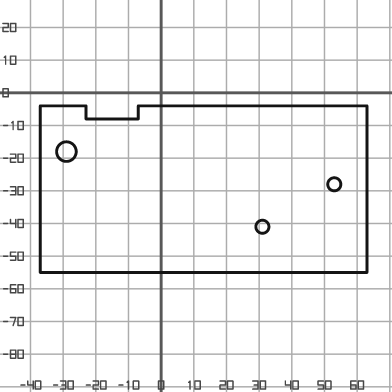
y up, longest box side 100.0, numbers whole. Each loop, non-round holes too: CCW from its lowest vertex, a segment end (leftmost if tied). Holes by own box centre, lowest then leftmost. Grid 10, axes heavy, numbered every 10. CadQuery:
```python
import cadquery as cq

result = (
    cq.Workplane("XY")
    .moveTo(-37.0, -55.0)
    .lineTo(63.0, -55.0)
    .lineTo(63.0, -4.0)
    .lineTo(-7.0, -4.0)
    .lineTo(-7.0, -8.0)
    .lineTo(-23.0, -8.0)
    .lineTo(-23.0, -4.0)
    .lineTo(-37.0, -4.0)
    .close()
    .moveTo(31.0, -41.0)
    .circle(2.0)
    .moveTo(53.0, -28.0)
    .circle(2.0)
    .moveTo(-29.0, -18.0)
    .circle(3.0)
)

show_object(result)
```